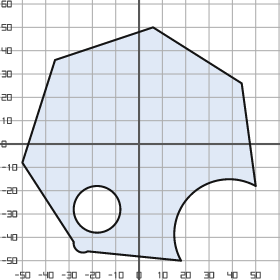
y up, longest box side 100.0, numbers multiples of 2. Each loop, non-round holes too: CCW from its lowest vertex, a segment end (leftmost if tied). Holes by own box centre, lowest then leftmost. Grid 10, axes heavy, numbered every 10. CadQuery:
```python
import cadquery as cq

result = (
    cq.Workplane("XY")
    .moveTo(18.0, -50.0)
    .threePointArc((22.0, -22.0), (50.0, -18.0))
    .lineTo(44.0, 26.0)
    .lineTo(6.0, 50.0)
    .lineTo(-36.0, 36.0)
    .lineTo(-50.0, -8.0)
    .lineTo(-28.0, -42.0)
    .threePointArc((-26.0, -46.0), (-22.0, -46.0))
    .close()
    .moveTo(-18.0, -28.0)
    .circle(10.0)
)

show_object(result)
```